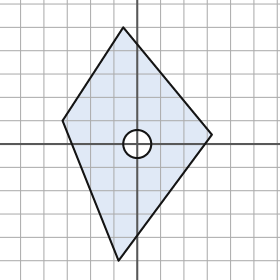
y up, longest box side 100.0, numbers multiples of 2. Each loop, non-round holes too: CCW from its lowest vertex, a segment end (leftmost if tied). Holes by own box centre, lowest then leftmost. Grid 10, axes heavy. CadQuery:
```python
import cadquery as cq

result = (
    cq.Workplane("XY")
    .moveTo(-8.0, -50.0)
    .lineTo(32.0, 4.0)
    .lineTo(-6.0, 50.0)
    .lineTo(-32.0, 10.0)
    .close()
    .moveTo(0.0, 0.0)
    .circle(6.0)
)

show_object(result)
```